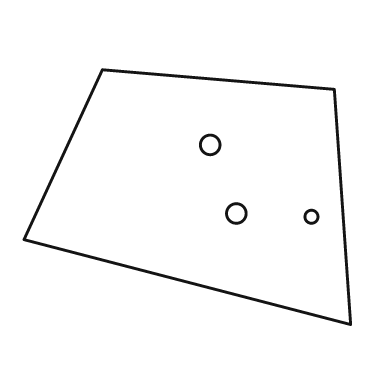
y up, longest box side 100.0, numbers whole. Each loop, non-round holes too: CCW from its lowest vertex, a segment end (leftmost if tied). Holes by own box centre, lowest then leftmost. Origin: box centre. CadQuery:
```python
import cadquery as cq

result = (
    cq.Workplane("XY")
    .moveTo(50.0, -39.0)
    .lineTo(45.0, 33.0)
    .lineTo(-26.0, 39.0)
    .lineTo(-50.0, -13.0)
    .close()
    .moveTo(38.0, -6.0)
    .circle(2.0)
    .moveTo(15.0, -5.0)
    .circle(3.0)
    .moveTo(7.0, 16.0)
    .circle(3.0)
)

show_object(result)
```